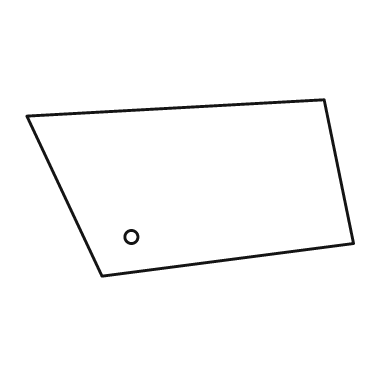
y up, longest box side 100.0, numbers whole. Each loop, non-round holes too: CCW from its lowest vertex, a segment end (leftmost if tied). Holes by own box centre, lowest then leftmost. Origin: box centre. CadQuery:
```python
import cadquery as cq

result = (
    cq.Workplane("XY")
    .moveTo(-27.0, -27.0)
    .lineTo(50.0, -17.0)
    .lineTo(41.0, 27.0)
    .lineTo(-50.0, 22.0)
    .close()
    .moveTo(-18.0, -15.0)
    .circle(2.0)
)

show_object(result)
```